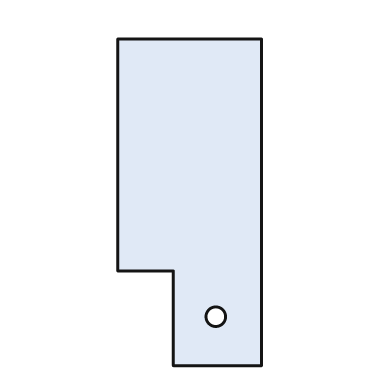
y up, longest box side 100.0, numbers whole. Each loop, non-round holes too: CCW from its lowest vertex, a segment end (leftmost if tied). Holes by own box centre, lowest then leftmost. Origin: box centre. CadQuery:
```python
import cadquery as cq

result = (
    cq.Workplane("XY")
    .moveTo(-5.0, -50.0)
    .lineTo(22.0, -50.0)
    .lineTo(22.0, 50.0)
    .lineTo(-22.0, 50.0)
    .lineTo(-22.0, -21.0)
    .lineTo(-5.0, -21.0)
    .close()
    .moveTo(8.0, -35.0)
    .circle(3.0)
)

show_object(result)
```